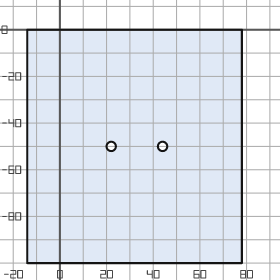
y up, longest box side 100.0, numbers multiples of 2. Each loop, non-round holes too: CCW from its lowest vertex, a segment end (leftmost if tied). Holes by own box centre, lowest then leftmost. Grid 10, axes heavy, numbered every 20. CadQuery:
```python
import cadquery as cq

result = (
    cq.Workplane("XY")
    .moveTo(-14.0, -100.0)
    .lineTo(78.0, -100.0)
    .lineTo(78.0, 0.0)
    .lineTo(-14.0, 0.0)
    .close()
    .moveTo(22.0, -50.0)
    .circle(2.0)
    .moveTo(44.0, -50.0)
    .circle(2.0)
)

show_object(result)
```